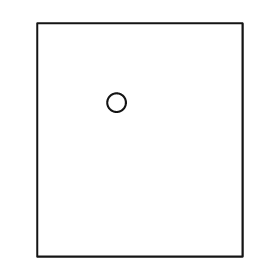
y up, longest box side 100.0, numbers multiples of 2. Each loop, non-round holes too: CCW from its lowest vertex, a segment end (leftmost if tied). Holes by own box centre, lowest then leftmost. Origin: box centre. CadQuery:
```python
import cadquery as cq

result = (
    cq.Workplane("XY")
    .moveTo(-44.0, -50.0)
    .lineTo(44.0, -50.0)
    .lineTo(44.0, 50.0)
    .lineTo(-44.0, 50.0)
    .close()
    .moveTo(-10.0, 16.0)
    .circle(4.0)
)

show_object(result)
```